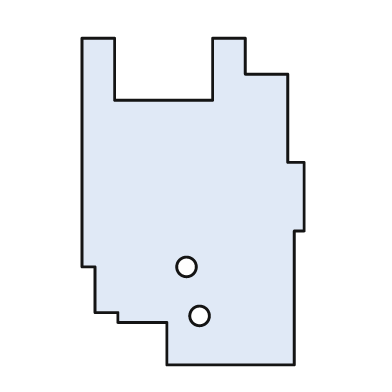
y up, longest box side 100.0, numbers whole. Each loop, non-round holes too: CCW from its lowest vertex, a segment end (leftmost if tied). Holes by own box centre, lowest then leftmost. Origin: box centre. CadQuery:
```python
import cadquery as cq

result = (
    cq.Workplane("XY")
    .moveTo(-8.0, -50.0)
    .lineTo(31.0, -50.0)
    .lineTo(31.0, -9.0)
    .lineTo(34.0, -9.0)
    .lineTo(34.0, 12.0)
    .lineTo(29.0, 12.0)
    .lineTo(29.0, 39.0)
    .lineTo(16.0, 39.0)
    .lineTo(16.0, 50.0)
    .lineTo(6.0, 50.0)
    .lineTo(6.0, 31.0)
    .lineTo(-24.0, 31.0)
    .lineTo(-24.0, 50.0)
    .lineTo(-34.0, 50.0)
    .lineTo(-34.0, -20.0)
    .lineTo(-30.0, -20.0)
    .lineTo(-30.0, -34.0)
    .lineTo(-23.0, -34.0)
    .lineTo(-23.0, -37.0)
    .lineTo(-8.0, -37.0)
    .close()
    .moveTo(2.0, -35.0)
    .circle(3.0)
    .moveTo(-2.0, -20.0)
    .circle(3.0)
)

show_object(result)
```